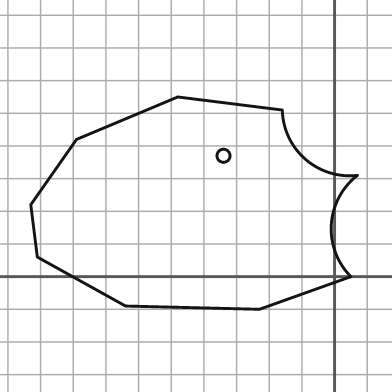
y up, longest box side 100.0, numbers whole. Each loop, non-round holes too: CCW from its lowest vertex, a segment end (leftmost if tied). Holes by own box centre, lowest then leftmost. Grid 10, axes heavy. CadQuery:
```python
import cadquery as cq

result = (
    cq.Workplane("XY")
    .moveTo(-23.0, -10.0)
    .lineTo(5.0, 0.0)
    .threePointArc((-1.0, 16.0), (7.0, 31.0))
    .threePointArc((-9.0, 36.0), (-16.0, 51.0))
    .lineTo(-48.0, 55.0)
    .lineTo(-79.0, 42.0)
    .lineTo(-93.0, 22.0)
    .lineTo(-91.0, 6.0)
    .lineTo(-64.0, -9.0)
    .close()
    .moveTo(-34.0, 37.0)
    .circle(2.0)
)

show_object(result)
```